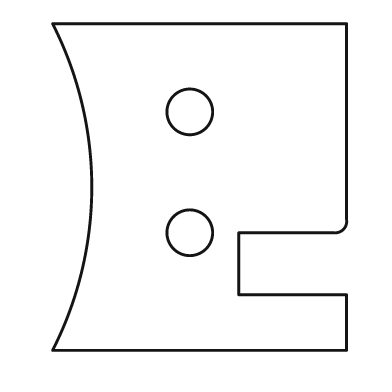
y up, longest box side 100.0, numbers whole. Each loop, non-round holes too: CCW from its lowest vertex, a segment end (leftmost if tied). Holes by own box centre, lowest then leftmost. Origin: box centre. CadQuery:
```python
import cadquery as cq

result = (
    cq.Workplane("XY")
    .moveTo(-45.0, -50.0)
    .lineTo(45.0, -50.0)
    .lineTo(45.0, -33.0)
    .lineTo(12.0, -33.0)
    .lineTo(12.0, -14.0)
    .lineTo(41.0, -14.0)
    .threePointArc((44.0, -13.0), (45.0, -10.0))
    .lineTo(45.0, 50.0)
    .lineTo(-45.0, 50.0)
    .threePointArc((-33.0, 0.0), (-45.0, -50.0))
    .close()
    .moveTo(-3.0, -14.0)
    .circle(7.0)
    .moveTo(-3.0, 23.0)
    .circle(7.0)
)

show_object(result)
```